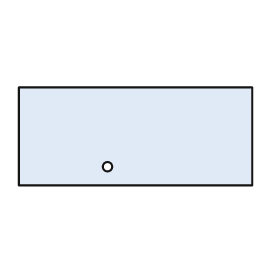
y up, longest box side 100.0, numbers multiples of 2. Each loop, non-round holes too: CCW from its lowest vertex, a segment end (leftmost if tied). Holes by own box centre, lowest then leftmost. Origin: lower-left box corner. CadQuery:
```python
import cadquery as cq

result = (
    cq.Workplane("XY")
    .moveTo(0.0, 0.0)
    .lineTo(100.0, 0.0)
    .lineTo(100.0, 42.0)
    .lineTo(0.0, 42.0)
    .close()
    .moveTo(38.0, 8.0)
    .circle(2.0)
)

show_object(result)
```